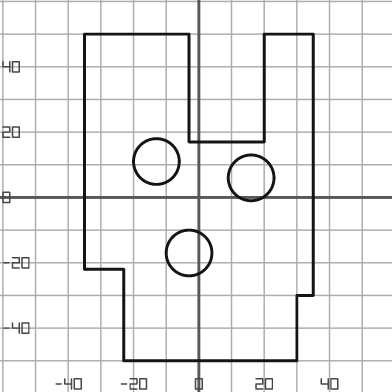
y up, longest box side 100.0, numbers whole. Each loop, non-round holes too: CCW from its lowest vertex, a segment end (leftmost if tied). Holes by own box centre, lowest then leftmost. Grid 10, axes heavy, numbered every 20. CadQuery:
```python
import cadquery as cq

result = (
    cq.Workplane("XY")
    .moveTo(-23.0, -50.0)
    .lineTo(30.0, -50.0)
    .lineTo(30.0, -30.0)
    .lineTo(35.0, -30.0)
    .lineTo(35.0, 50.0)
    .lineTo(20.0, 50.0)
    .lineTo(20.0, 17.0)
    .lineTo(-3.0, 17.0)
    .lineTo(-3.0, 50.0)
    .lineTo(-35.0, 50.0)
    .lineTo(-35.0, -22.0)
    .lineTo(-23.0, -22.0)
    .close()
    .moveTo(-3.0, -17.0)
    .circle(7.0)
    .moveTo(16.0, 6.0)
    .circle(7.0)
    .moveTo(-13.0, 11.0)
    .circle(7.0)
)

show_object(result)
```